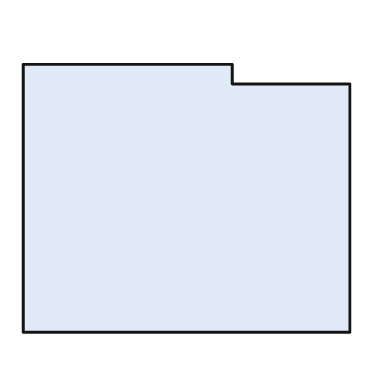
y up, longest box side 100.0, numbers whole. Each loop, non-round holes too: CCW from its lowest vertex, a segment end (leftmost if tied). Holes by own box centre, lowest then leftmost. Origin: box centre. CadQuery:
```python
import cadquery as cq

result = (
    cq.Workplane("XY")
    .moveTo(-50.0, -41.0)
    .lineTo(50.0, -41.0)
    .lineTo(50.0, 35.0)
    .lineTo(14.0, 35.0)
    .lineTo(14.0, 41.0)
    .lineTo(-50.0, 41.0)
    .close()
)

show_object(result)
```